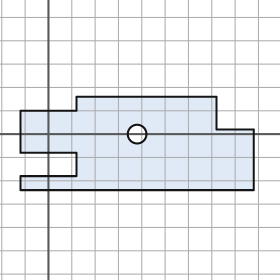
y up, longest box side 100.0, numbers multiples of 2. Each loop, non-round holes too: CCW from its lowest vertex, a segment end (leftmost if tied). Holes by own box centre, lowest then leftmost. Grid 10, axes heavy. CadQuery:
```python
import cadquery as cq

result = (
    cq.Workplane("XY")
    .moveTo(-12.0, -24.0)
    .lineTo(88.0, -24.0)
    .lineTo(88.0, 2.0)
    .lineTo(72.0, 2.0)
    .lineTo(72.0, 16.0)
    .lineTo(12.0, 16.0)
    .lineTo(12.0, 10.0)
    .lineTo(-12.0, 10.0)
    .lineTo(-12.0, -8.0)
    .lineTo(12.0, -8.0)
    .lineTo(12.0, -18.0)
    .lineTo(-12.0, -18.0)
    .close()
    .moveTo(38.0, 0.0)
    .circle(4.0)
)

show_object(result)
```